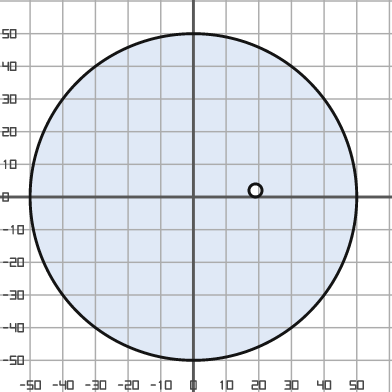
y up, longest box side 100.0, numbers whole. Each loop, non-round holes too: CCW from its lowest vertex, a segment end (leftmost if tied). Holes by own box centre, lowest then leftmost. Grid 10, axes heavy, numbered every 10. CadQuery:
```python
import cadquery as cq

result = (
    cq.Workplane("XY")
    .moveTo(0.0, 0.0)
    .circle(50.0)
    .moveTo(19.0, 2.0)
    .circle(2.0)
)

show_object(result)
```